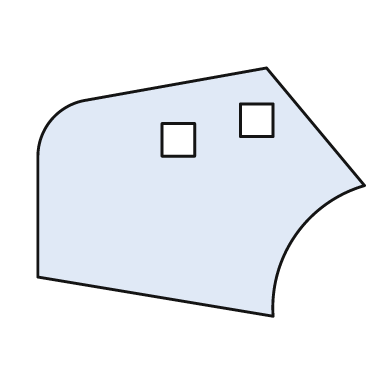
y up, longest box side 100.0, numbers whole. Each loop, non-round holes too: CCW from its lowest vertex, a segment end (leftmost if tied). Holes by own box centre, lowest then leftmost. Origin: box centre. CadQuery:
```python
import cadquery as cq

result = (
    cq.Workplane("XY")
    .moveTo(22.0, -38.0)
    .threePointArc((29.0, -13.0), (50.0, 2.0))
    .lineTo(20.0, 38.0)
    .lineTo(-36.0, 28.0)
    .threePointArc((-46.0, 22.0), (-50.0, 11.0))
    .lineTo(-50.0, -26.0)
    .close()
    .moveTo(-12.0, 11.0)
    .lineTo(-2.0, 11.0)
    .lineTo(-2.0, 21.0)
    .lineTo(-12.0, 21.0)
    .close()
    .moveTo(12.0, 17.0)
    .lineTo(22.0, 17.0)
    .lineTo(22.0, 27.0)
    .lineTo(12.0, 27.0)
    .close()
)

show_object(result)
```